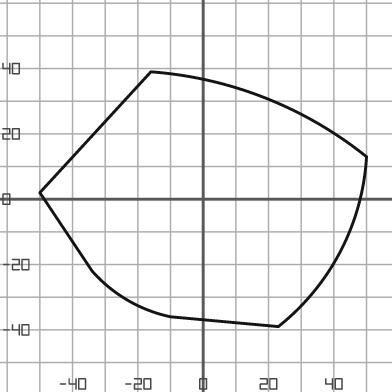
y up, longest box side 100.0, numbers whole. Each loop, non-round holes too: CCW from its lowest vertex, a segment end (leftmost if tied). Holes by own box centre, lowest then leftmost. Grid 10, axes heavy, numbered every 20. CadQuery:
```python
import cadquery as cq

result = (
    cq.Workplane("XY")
    .moveTo(23.0, -39.0)
    .threePointArc((42.0, -16.0), (50.0, 13.0))
    .threePointArc((19.0, 31.0), (-16.0, 39.0))
    .lineTo(-50.0, 2.0)
    .lineTo(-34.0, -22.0)
    .threePointArc((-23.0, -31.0), (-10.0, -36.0))
    .close()
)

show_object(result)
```